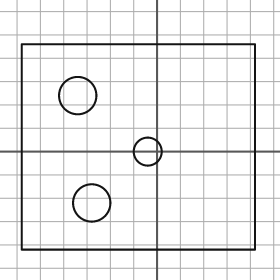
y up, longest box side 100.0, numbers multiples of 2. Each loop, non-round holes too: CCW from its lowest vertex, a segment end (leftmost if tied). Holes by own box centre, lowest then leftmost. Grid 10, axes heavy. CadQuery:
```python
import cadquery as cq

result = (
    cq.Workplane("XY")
    .moveTo(-58.0, -42.0)
    .lineTo(42.0, -42.0)
    .lineTo(42.0, 46.0)
    .lineTo(-58.0, 46.0)
    .close()
    .moveTo(-28.0, -22.0)
    .circle(8.0)
    .moveTo(-4.0, 0.0)
    .circle(6.0)
    .moveTo(-34.0, 24.0)
    .circle(8.0)
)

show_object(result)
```